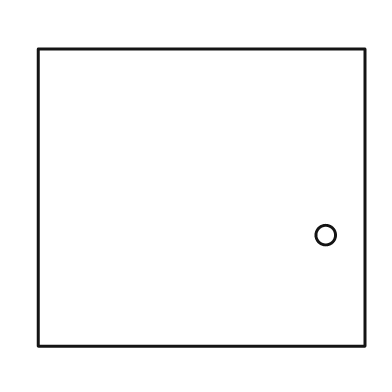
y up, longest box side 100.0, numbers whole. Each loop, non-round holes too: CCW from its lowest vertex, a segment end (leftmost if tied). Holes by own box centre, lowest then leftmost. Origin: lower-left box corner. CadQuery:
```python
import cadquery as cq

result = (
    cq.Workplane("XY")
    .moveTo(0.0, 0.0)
    .lineTo(100.0, 0.0)
    .lineTo(100.0, 91.0)
    .lineTo(0.0, 91.0)
    .close()
    .moveTo(88.0, 34.0)
    .circle(3.0)
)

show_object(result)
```